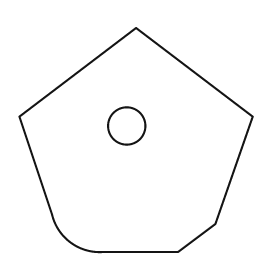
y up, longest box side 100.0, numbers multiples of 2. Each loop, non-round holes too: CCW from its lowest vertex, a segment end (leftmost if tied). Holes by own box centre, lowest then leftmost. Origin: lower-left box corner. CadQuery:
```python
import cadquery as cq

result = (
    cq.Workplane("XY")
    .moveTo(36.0, 0.0)
    .lineTo(68.0, 0.0)
    .lineTo(84.0, 12.0)
    .lineTo(100.0, 58.0)
    .lineTo(50.0, 96.0)
    .lineTo(0.0, 58.0)
    .lineTo(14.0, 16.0)
    .threePointArc((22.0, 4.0), (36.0, 0.0))
    .close()
    .moveTo(46.0, 54.0)
    .circle(8.0)
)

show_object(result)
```